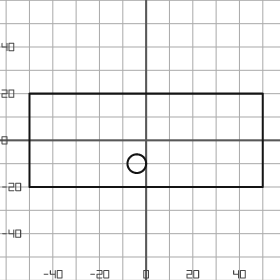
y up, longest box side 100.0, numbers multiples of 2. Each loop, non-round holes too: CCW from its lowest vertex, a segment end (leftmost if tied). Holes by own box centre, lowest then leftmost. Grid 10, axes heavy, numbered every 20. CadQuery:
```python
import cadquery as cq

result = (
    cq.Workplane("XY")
    .moveTo(-50.0, -20.0)
    .lineTo(50.0, -20.0)
    .lineTo(50.0, 20.0)
    .lineTo(-50.0, 20.0)
    .close()
    .moveTo(-4.0, -10.0)
    .circle(4.0)
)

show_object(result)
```